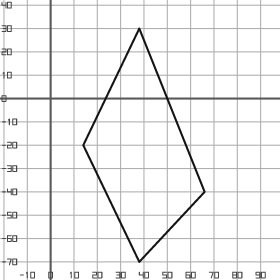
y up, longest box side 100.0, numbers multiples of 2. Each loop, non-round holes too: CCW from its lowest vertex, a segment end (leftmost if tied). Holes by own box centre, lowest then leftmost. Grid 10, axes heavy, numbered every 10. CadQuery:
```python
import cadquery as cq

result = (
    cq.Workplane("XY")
    .moveTo(38.0, -70.0)
    .lineTo(66.0, -40.0)
    .lineTo(38.0, 30.0)
    .lineTo(14.0, -20.0)
    .close()
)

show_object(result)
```